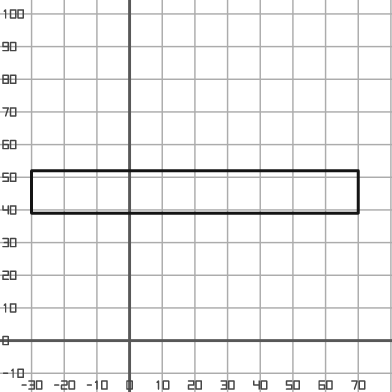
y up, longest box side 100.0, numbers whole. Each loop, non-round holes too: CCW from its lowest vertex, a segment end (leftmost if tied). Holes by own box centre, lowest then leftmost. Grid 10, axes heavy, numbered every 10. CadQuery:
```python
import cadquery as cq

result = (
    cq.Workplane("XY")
    .moveTo(-30.0, 39.0)
    .lineTo(70.0, 39.0)
    .lineTo(70.0, 52.0)
    .lineTo(-30.0, 52.0)
    .close()
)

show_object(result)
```